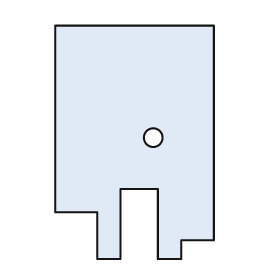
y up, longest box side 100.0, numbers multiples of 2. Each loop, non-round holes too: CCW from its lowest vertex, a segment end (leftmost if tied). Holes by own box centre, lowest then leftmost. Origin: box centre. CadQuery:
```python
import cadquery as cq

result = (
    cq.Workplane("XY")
    .moveTo(-16.0, -50.0)
    .lineTo(-6.0, -50.0)
    .lineTo(-6.0, -20.0)
    .lineTo(10.0, -20.0)
    .lineTo(10.0, -50.0)
    .lineTo(20.0, -50.0)
    .lineTo(20.0, -42.0)
    .lineTo(34.0, -42.0)
    .lineTo(34.0, 50.0)
    .lineTo(-34.0, 50.0)
    .lineTo(-34.0, -30.0)
    .lineTo(-16.0, -30.0)
    .close()
    .moveTo(8.0, 2.0)
    .circle(4.0)
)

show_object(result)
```